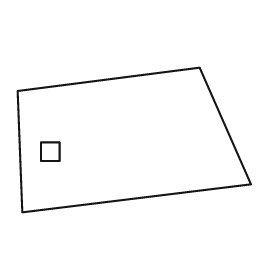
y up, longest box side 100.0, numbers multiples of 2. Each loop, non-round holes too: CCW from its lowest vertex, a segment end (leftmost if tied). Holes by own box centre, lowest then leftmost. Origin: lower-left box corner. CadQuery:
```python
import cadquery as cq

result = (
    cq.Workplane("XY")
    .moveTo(2.0, 0.0)
    .lineTo(100.0, 12.0)
    .lineTo(78.0, 62.0)
    .lineTo(0.0, 52.0)
    .close()
    .moveTo(10.0, 22.0)
    .lineTo(18.0, 22.0)
    .lineTo(18.0, 30.0)
    .lineTo(10.0, 30.0)
    .close()
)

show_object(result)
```